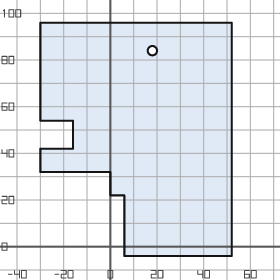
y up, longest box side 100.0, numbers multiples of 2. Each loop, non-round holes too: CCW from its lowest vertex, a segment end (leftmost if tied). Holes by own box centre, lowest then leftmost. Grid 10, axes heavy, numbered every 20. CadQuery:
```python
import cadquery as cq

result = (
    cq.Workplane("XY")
    .moveTo(6.0, -4.0)
    .lineTo(52.0, -4.0)
    .lineTo(52.0, 96.0)
    .lineTo(-30.0, 96.0)
    .lineTo(-30.0, 54.0)
    .lineTo(-16.0, 54.0)
    .lineTo(-16.0, 42.0)
    .lineTo(-30.0, 42.0)
    .lineTo(-30.0, 32.0)
    .lineTo(0.0, 32.0)
    .lineTo(0.0, 22.0)
    .lineTo(6.0, 22.0)
    .close()
    .moveTo(18.0, 84.0)
    .circle(2.0)
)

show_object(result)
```